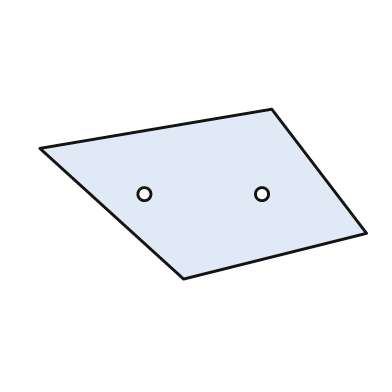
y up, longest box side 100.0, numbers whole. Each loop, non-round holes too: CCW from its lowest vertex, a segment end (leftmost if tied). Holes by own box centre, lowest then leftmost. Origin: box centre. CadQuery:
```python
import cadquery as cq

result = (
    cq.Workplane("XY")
    .moveTo(-6.0, -26.0)
    .lineTo(50.0, -12.0)
    .lineTo(21.0, 26.0)
    .lineTo(-50.0, 14.0)
    .close()
    .moveTo(-18.0, 0.0)
    .circle(2.0)
    .moveTo(18.0, 0.0)
    .circle(2.0)
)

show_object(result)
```